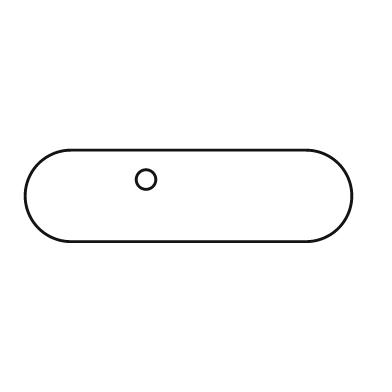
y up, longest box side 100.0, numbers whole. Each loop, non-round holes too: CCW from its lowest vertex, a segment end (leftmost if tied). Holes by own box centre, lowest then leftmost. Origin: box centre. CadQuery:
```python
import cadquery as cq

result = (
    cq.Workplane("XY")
    .moveTo(-36.0, -14.0)
    .lineTo(36.0, -14.0)
    .threePointArc((50.0, 0.0), (36.0, 14.0))
    .lineTo(-36.0, 14.0)
    .threePointArc((-50.0, 0.0), (-36.0, -14.0))
    .close()
    .moveTo(-13.0, 5.0)
    .circle(3.0)
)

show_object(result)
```